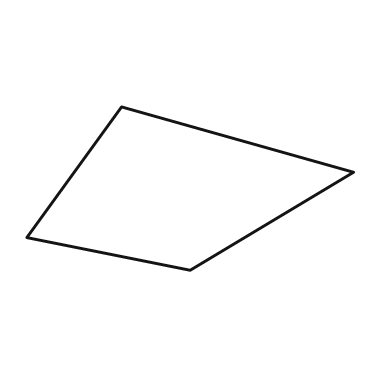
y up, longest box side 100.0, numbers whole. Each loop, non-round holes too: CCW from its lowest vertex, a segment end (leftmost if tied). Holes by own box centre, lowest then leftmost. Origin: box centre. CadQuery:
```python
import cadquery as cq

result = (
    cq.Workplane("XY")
    .moveTo(0.0, -25.0)
    .lineTo(50.0, 5.0)
    .lineTo(-21.0, 25.0)
    .lineTo(-50.0, -15.0)
    .close()
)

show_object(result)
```